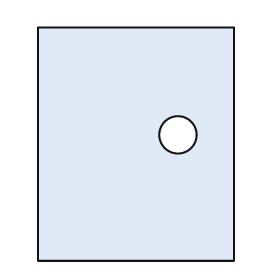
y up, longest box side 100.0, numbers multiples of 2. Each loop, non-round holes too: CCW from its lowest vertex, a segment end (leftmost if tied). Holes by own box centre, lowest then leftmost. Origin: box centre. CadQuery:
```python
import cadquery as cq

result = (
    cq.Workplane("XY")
    .moveTo(-42.0, -50.0)
    .lineTo(42.0, -50.0)
    .lineTo(42.0, 50.0)
    .lineTo(-42.0, 50.0)
    .close()
    .moveTo(18.0, 4.0)
    .circle(8.0)
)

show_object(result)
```